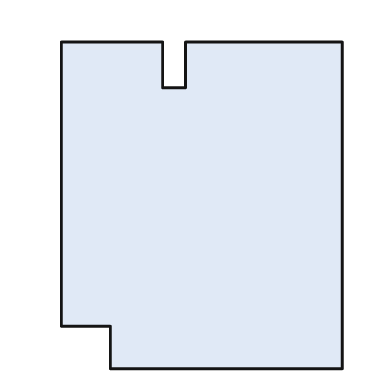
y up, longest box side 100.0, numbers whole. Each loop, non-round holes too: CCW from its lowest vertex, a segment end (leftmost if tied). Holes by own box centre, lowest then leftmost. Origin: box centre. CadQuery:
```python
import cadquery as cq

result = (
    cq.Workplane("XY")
    .moveTo(-28.0, -50.0)
    .lineTo(43.0, -50.0)
    .lineTo(43.0, 50.0)
    .lineTo(-5.0, 50.0)
    .lineTo(-5.0, 36.0)
    .lineTo(-12.0, 36.0)
    .lineTo(-12.0, 50.0)
    .lineTo(-43.0, 50.0)
    .lineTo(-43.0, -37.0)
    .lineTo(-28.0, -37.0)
    .close()
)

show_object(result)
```